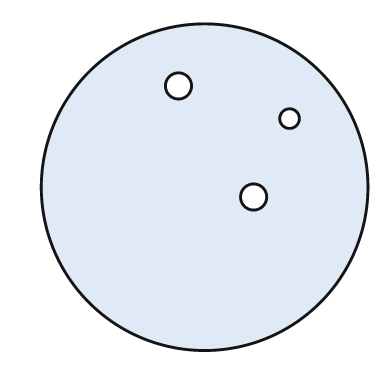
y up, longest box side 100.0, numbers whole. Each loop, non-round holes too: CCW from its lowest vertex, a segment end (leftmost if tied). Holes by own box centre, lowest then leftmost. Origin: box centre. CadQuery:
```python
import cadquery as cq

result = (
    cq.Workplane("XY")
    .moveTo(0.0, 0.0)
    .circle(50.0)
    .moveTo(15.0, -3.0)
    .circle(4.0)
    .moveTo(26.0, 21.0)
    .circle(3.0)
    .moveTo(-8.0, 31.0)
    .circle(4.0)
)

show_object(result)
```